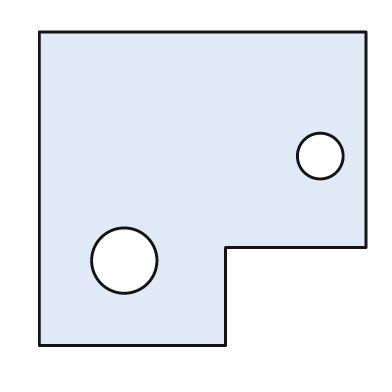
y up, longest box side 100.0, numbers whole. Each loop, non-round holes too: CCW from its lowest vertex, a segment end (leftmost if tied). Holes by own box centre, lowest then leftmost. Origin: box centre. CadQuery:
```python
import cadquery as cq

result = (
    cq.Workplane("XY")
    .moveTo(-50.0, -48.0)
    .lineTo(7.0, -48.0)
    .lineTo(7.0, -18.0)
    .lineTo(50.0, -18.0)
    .lineTo(50.0, 48.0)
    .lineTo(-50.0, 48.0)
    .close()
    .moveTo(-24.0, -22.0)
    .circle(10.0)
    .moveTo(36.0, 10.0)
    .circle(7.0)
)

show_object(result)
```